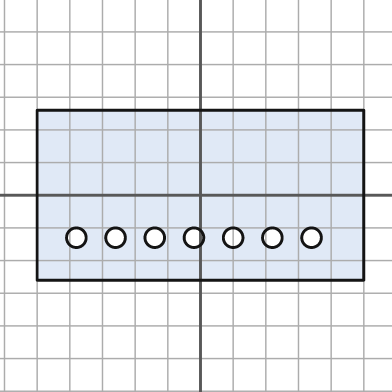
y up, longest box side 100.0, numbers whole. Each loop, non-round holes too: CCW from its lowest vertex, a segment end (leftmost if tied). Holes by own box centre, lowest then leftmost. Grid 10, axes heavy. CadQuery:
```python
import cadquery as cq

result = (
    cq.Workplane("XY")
    .moveTo(-50.0, -26.0)
    .lineTo(50.0, -26.0)
    .lineTo(50.0, 26.0)
    .lineTo(-50.0, 26.0)
    .close()
    .moveTo(-38.0, -13.0)
    .circle(3.0)
    .moveTo(-26.0, -13.0)
    .circle(3.0)
    .moveTo(-14.0, -13.0)
    .circle(3.0)
    .moveTo(-2.0, -13.0)
    .circle(3.0)
    .moveTo(10.0, -13.0)
    .circle(3.0)
    .moveTo(22.0, -13.0)
    .circle(3.0)
    .moveTo(34.0, -13.0)
    .circle(3.0)
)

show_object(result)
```